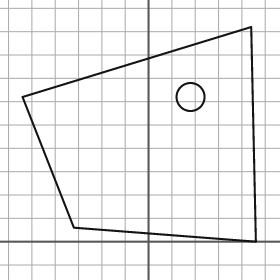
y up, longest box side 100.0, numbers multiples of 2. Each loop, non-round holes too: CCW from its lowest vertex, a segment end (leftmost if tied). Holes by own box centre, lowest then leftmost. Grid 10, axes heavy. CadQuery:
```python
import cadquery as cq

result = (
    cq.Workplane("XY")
    .moveTo(46.0, 0.0)
    .lineTo(44.0, 92.0)
    .lineTo(-54.0, 62.0)
    .lineTo(-32.0, 6.0)
    .close()
    .moveTo(18.0, 62.0)
    .circle(6.0)
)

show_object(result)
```